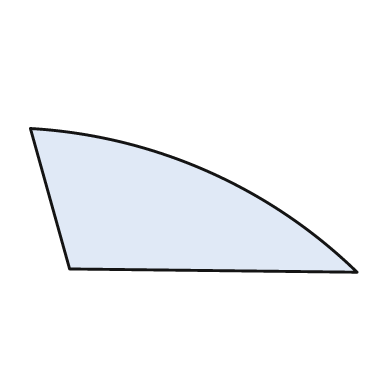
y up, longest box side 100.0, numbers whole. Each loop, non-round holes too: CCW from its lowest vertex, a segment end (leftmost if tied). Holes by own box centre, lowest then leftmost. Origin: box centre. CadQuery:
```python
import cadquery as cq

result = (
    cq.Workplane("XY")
    .moveTo(50.0, -22.0)
    .threePointArc((4.0, 9.0), (-50.0, 22.0))
    .lineTo(-38.0, -21.0)
    .close()
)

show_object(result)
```